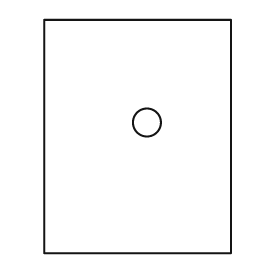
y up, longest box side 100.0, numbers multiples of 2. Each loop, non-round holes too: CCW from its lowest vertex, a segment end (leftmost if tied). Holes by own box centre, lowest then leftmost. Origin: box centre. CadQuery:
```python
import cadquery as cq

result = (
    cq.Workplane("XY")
    .moveTo(-40.0, -50.0)
    .lineTo(40.0, -50.0)
    .lineTo(40.0, 50.0)
    .lineTo(-40.0, 50.0)
    .close()
    .moveTo(4.0, 6.0)
    .circle(6.0)
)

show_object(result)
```